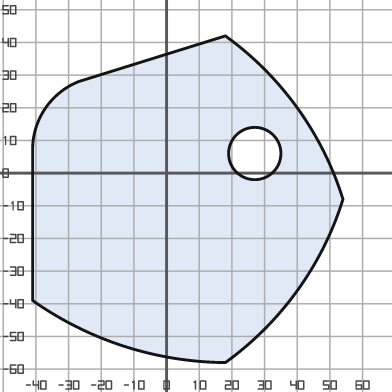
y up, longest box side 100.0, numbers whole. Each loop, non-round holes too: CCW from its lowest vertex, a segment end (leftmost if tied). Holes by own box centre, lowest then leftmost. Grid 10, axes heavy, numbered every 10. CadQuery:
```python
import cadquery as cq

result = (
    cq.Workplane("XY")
    .moveTo(18.0, -58.0)
    .threePointArc((40.0, -36.0), (54.0, -8.0))
    .threePointArc((40.0, 20.0), (18.0, 42.0))
    .lineTo(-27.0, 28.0)
    .threePointArc((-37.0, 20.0), (-41.0, 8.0))
    .lineTo(-41.0, -39.0)
    .threePointArc((-13.0, -53.0), (18.0, -58.0))
    .close()
    .moveTo(27.0, 6.0)
    .circle(8.0)
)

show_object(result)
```